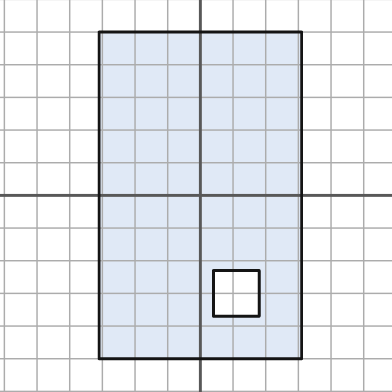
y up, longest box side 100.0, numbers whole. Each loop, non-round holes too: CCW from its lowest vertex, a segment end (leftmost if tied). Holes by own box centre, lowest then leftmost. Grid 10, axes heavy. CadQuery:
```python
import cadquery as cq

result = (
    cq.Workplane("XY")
    .moveTo(-31.0, -50.0)
    .lineTo(31.0, -50.0)
    .lineTo(31.0, 50.0)
    .lineTo(-31.0, 50.0)
    .close()
    .moveTo(4.0, -37.0)
    .lineTo(18.0, -37.0)
    .lineTo(18.0, -23.0)
    .lineTo(4.0, -23.0)
    .close()
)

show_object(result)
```